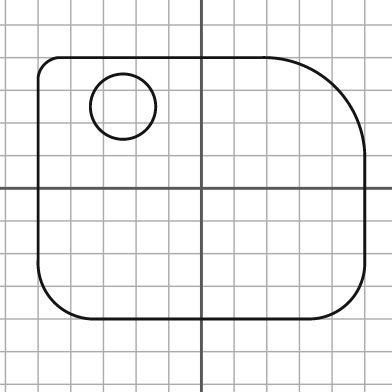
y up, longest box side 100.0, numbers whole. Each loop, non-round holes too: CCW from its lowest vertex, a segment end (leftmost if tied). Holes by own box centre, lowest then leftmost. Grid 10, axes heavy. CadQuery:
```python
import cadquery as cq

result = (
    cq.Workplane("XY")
    .moveTo(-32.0, -40.0)
    .lineTo(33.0, -40.0)
    .threePointArc((45.0, -35.0), (50.0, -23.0))
    .lineTo(50.0, 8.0)
    .threePointArc((41.0, 31.0), (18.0, 40.0))
    .lineTo(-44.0, 40.0)
    .threePointArc((-48.0, 38.0), (-50.0, 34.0))
    .lineTo(-50.0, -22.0)
    .threePointArc((-45.0, -35.0), (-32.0, -40.0))
    .close()
    .moveTo(-24.0, 25.0)
    .circle(10.0)
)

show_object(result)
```